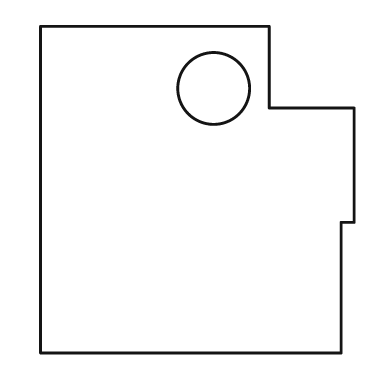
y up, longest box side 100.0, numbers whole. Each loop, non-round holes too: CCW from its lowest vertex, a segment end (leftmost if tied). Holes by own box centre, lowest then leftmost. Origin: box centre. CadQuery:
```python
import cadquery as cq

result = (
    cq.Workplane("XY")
    .moveTo(-48.0, -50.0)
    .lineTo(44.0, -50.0)
    .lineTo(44.0, -10.0)
    .lineTo(48.0, -10.0)
    .lineTo(48.0, 25.0)
    .lineTo(22.0, 25.0)
    .lineTo(22.0, 50.0)
    .lineTo(-48.0, 50.0)
    .close()
    .moveTo(5.0, 31.0)
    .circle(11.0)
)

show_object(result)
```